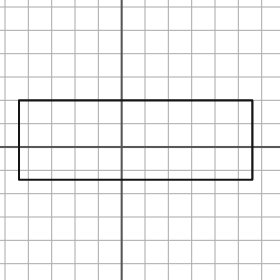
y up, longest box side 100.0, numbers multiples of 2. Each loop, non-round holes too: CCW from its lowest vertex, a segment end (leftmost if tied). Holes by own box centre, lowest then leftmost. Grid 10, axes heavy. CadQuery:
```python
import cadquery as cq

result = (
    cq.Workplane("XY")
    .moveTo(-44.0, -14.0)
    .lineTo(56.0, -14.0)
    .lineTo(56.0, 20.0)
    .lineTo(-44.0, 20.0)
    .close()
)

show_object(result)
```